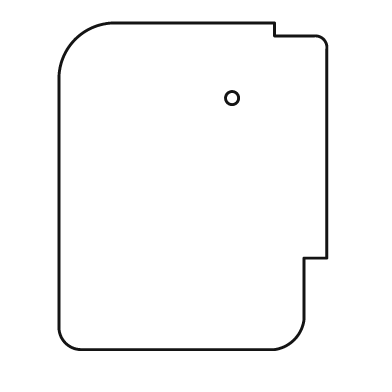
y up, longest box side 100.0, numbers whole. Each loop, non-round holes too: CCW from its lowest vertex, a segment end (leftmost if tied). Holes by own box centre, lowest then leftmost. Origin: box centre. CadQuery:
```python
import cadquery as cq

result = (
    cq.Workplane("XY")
    .moveTo(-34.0, -50.0)
    .lineTo(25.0, -50.0)
    .threePointArc((31.0, -47.0), (34.0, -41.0))
    .lineTo(34.0, -22.0)
    .lineTo(41.0, -22.0)
    .lineTo(41.0, 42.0)
    .threePointArc((40.0, 45.0), (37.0, 46.0))
    .lineTo(25.0, 46.0)
    .lineTo(25.0, 50.0)
    .lineTo(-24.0, 50.0)
    .threePointArc((-36.0, 45.0), (-41.0, 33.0))
    .lineTo(-41.0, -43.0)
    .threePointArc((-39.0, -48.0), (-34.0, -50.0))
    .close()
    .moveTo(12.0, 27.0)
    .circle(2.0)
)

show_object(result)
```